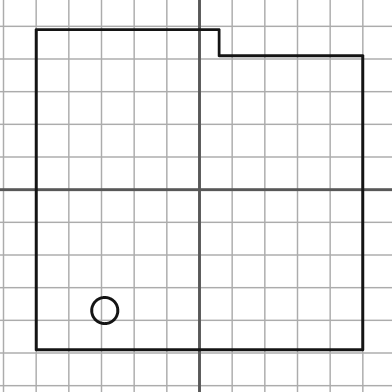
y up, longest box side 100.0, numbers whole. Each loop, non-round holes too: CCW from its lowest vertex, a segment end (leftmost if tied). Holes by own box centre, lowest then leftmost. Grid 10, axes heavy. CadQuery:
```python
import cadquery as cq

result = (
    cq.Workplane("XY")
    .moveTo(-50.0, -49.0)
    .lineTo(50.0, -49.0)
    .lineTo(50.0, 41.0)
    .lineTo(6.0, 41.0)
    .lineTo(6.0, 49.0)
    .lineTo(-50.0, 49.0)
    .close()
    .moveTo(-29.0, -37.0)
    .circle(4.0)
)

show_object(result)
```